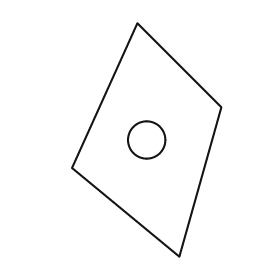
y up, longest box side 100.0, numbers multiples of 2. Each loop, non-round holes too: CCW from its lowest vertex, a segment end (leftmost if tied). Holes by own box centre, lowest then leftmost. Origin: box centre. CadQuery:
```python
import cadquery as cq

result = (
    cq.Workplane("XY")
    .moveTo(14.0, -50.0)
    .lineTo(32.0, 14.0)
    .lineTo(-4.0, 50.0)
    .lineTo(-32.0, -12.0)
    .close()
    .moveTo(0.0, 0.0)
    .circle(8.0)
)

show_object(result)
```